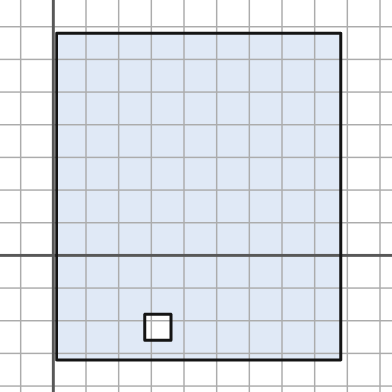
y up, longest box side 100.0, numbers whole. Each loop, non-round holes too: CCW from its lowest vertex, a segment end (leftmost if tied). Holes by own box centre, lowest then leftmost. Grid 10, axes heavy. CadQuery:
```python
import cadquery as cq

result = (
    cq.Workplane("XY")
    .moveTo(1.0, -32.0)
    .lineTo(88.0, -32.0)
    .lineTo(88.0, 68.0)
    .lineTo(1.0, 68.0)
    .close()
    .moveTo(28.0, -26.0)
    .lineTo(36.0, -26.0)
    .lineTo(36.0, -18.0)
    .lineTo(28.0, -18.0)
    .close()
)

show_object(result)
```